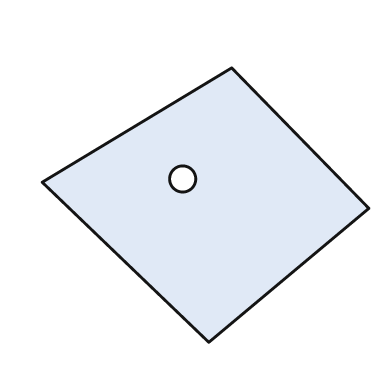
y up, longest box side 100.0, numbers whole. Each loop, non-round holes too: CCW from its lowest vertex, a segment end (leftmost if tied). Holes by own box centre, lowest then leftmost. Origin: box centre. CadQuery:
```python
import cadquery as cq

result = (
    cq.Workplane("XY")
    .moveTo(1.0, -42.0)
    .lineTo(50.0, -1.0)
    .lineTo(8.0, 42.0)
    .lineTo(-50.0, 7.0)
    .close()
    .moveTo(-7.0, 8.0)
    .circle(4.0)
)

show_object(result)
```